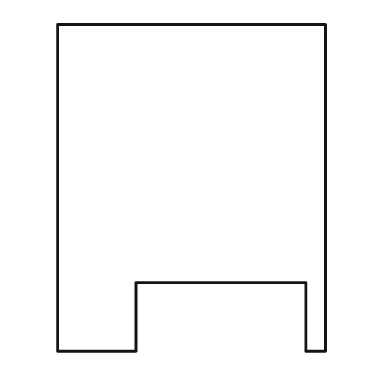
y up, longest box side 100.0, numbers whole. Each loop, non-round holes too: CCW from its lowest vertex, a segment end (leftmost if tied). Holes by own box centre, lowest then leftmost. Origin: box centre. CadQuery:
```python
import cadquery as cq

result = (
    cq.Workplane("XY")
    .moveTo(-41.0, -50.0)
    .lineTo(-17.0, -50.0)
    .lineTo(-17.0, -29.0)
    .lineTo(35.0, -29.0)
    .lineTo(35.0, -50.0)
    .lineTo(41.0, -50.0)
    .lineTo(41.0, 50.0)
    .lineTo(-41.0, 50.0)
    .close()
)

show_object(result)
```